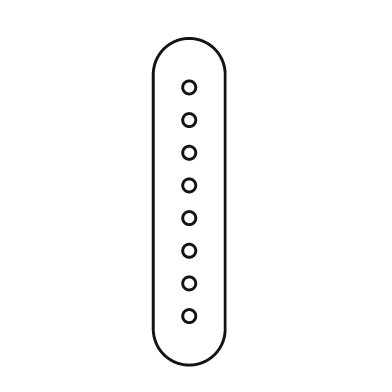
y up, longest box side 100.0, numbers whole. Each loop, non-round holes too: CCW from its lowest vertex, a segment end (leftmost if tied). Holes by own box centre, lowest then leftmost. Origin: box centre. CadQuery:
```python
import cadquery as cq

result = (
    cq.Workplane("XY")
    .moveTo(-11.0, -39.0)
    .threePointArc((0.0, -50.0), (11.0, -39.0))
    .lineTo(11.0, 39.0)
    .threePointArc((0.0, 50.0), (-11.0, 39.0))
    .close()
    .moveTo(0.0, -35.0)
    .circle(2.0)
    .moveTo(0.0, -25.0)
    .circle(2.0)
    .moveTo(0.0, -15.0)
    .circle(2.0)
    .moveTo(0.0, -5.0)
    .circle(2.0)
    .moveTo(0.0, 5.0)
    .circle(2.0)
    .moveTo(0.0, 15.0)
    .circle(2.0)
    .moveTo(0.0, 25.0)
    .circle(2.0)
    .moveTo(0.0, 35.0)
    .circle(2.0)
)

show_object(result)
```